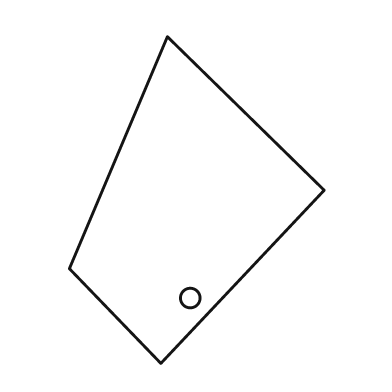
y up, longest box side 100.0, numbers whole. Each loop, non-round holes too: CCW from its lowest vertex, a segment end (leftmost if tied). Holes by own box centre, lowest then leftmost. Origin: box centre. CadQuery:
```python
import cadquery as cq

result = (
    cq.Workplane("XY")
    .moveTo(-11.0, -50.0)
    .lineTo(39.0, 3.0)
    .lineTo(-9.0, 50.0)
    .lineTo(-39.0, -21.0)
    .close()
    .moveTo(-2.0, -30.0)
    .circle(3.0)
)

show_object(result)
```